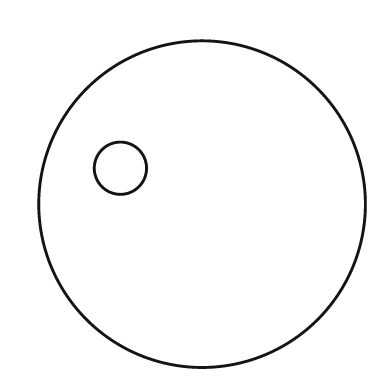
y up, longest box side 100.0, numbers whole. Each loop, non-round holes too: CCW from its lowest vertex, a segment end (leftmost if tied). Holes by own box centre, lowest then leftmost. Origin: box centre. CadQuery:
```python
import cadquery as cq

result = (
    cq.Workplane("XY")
    .moveTo(0.0, 0.0)
    .circle(50.0)
    .moveTo(-25.0, 11.0)
    .circle(8.0)
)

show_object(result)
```